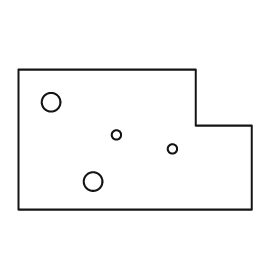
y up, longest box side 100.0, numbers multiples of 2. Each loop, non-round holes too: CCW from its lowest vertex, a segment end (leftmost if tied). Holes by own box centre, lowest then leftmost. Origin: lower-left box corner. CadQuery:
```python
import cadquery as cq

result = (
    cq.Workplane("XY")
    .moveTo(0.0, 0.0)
    .lineTo(100.0, 0.0)
    .lineTo(100.0, 36.0)
    .lineTo(76.0, 36.0)
    .lineTo(76.0, 60.0)
    .lineTo(0.0, 60.0)
    .close()
    .moveTo(32.0, 12.0)
    .circle(4.0)
    .moveTo(66.0, 26.0)
    .circle(2.0)
    .moveTo(42.0, 32.0)
    .circle(2.0)
    .moveTo(14.0, 46.0)
    .circle(4.0)
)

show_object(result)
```